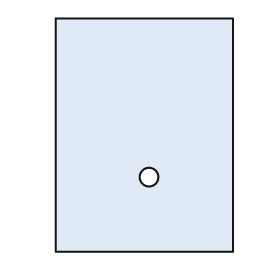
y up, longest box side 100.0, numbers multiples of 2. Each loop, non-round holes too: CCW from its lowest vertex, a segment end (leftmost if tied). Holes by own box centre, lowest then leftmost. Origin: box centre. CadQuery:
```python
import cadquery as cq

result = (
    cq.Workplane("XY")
    .moveTo(-38.0, -50.0)
    .lineTo(38.0, -50.0)
    .lineTo(38.0, 50.0)
    .lineTo(-38.0, 50.0)
    .close()
    .moveTo(2.0, -18.0)
    .circle(4.0)
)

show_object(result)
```